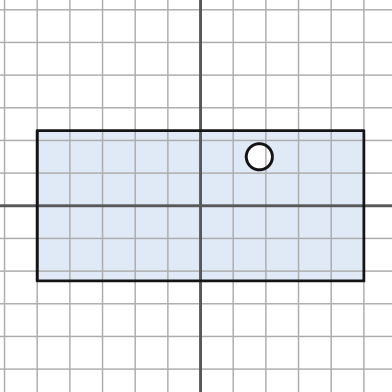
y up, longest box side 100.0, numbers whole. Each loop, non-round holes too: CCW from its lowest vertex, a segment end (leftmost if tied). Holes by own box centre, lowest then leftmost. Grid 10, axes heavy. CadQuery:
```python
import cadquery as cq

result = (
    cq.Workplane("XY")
    .moveTo(-50.0, -23.0)
    .lineTo(50.0, -23.0)
    .lineTo(50.0, 23.0)
    .lineTo(-50.0, 23.0)
    .close()
    .moveTo(18.0, 15.0)
    .circle(4.0)
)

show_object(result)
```